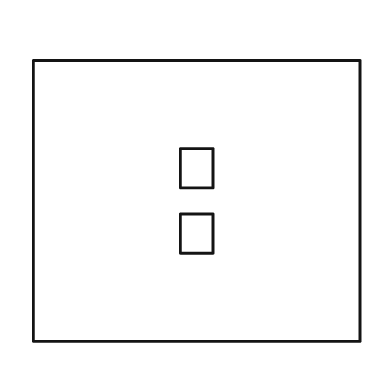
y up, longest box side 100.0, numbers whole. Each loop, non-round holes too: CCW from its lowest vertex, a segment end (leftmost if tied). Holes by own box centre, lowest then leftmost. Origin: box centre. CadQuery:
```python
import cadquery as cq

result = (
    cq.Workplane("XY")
    .moveTo(-50.0, -43.0)
    .lineTo(50.0, -43.0)
    .lineTo(50.0, 43.0)
    .lineTo(-50.0, 43.0)
    .close()
    .moveTo(-5.0, -16.0)
    .lineTo(5.0, -16.0)
    .lineTo(5.0, -4.0)
    .lineTo(-5.0, -4.0)
    .close()
    .moveTo(-5.0, 4.0)
    .lineTo(5.0, 4.0)
    .lineTo(5.0, 16.0)
    .lineTo(-5.0, 16.0)
    .close()
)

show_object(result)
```